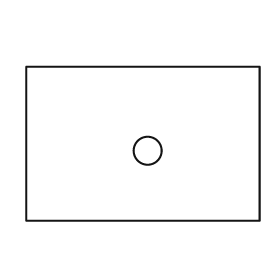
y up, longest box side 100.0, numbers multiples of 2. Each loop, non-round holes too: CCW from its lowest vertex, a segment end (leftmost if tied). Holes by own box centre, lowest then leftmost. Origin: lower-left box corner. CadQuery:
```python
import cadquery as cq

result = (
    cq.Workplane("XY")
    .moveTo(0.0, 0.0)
    .lineTo(100.0, 0.0)
    .lineTo(100.0, 66.0)
    .lineTo(0.0, 66.0)
    .close()
    .moveTo(52.0, 30.0)
    .circle(6.0)
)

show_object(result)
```